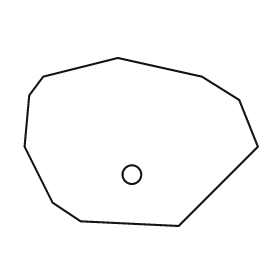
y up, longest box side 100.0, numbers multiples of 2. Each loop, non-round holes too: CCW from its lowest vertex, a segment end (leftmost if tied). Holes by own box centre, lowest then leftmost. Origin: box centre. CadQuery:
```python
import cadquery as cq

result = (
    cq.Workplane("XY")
    .moveTo(16.0, -36.0)
    .lineTo(50.0, -2.0)
    .lineTo(42.0, 18.0)
    .lineTo(26.0, 28.0)
    .lineTo(-10.0, 36.0)
    .lineTo(-42.0, 28.0)
    .lineTo(-48.0, 20.0)
    .lineTo(-50.0, -2.0)
    .lineTo(-38.0, -26.0)
    .lineTo(-26.0, -34.0)
    .close()
    .moveTo(-4.0, -14.0)
    .circle(4.0)
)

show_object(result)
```